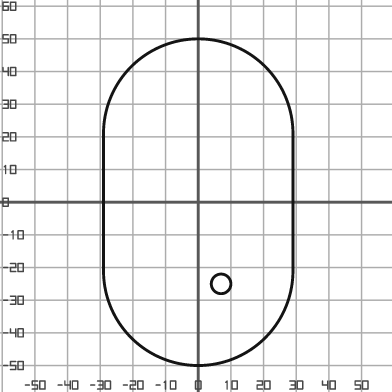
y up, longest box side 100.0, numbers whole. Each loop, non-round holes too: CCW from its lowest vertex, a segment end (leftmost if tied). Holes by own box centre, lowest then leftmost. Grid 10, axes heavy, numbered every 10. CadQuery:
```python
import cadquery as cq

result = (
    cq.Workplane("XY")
    .moveTo(-29.0, -21.0)
    .threePointArc((0.0, -50.0), (29.0, -21.0))
    .lineTo(29.0, 21.0)
    .threePointArc((0.0, 50.0), (-29.0, 21.0))
    .close()
    .moveTo(7.0, -25.0)
    .circle(3.0)
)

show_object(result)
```